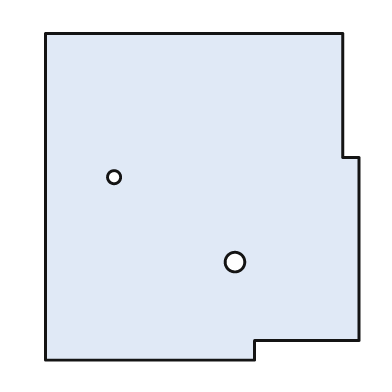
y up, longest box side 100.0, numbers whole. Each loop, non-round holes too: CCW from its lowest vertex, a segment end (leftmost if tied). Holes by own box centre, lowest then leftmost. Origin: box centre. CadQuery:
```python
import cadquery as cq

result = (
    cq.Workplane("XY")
    .moveTo(-48.0, -50.0)
    .lineTo(16.0, -50.0)
    .lineTo(16.0, -44.0)
    .lineTo(48.0, -44.0)
    .lineTo(48.0, 12.0)
    .lineTo(43.0, 12.0)
    .lineTo(43.0, 50.0)
    .lineTo(-48.0, 50.0)
    .close()
    .moveTo(10.0, -20.0)
    .circle(3.0)
    .moveTo(-27.0, 6.0)
    .circle(2.0)
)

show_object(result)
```